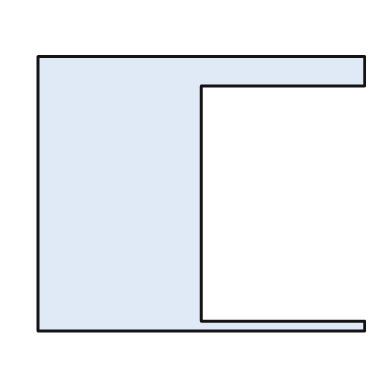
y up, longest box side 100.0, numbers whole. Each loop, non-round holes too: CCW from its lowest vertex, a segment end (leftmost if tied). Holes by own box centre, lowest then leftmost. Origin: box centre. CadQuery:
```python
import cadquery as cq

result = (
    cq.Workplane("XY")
    .moveTo(-50.0, -42.0)
    .lineTo(50.0, -42.0)
    .lineTo(50.0, -39.0)
    .lineTo(0.0, -39.0)
    .lineTo(0.0, 33.0)
    .lineTo(50.0, 33.0)
    .lineTo(50.0, 42.0)
    .lineTo(-50.0, 42.0)
    .close()
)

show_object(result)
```